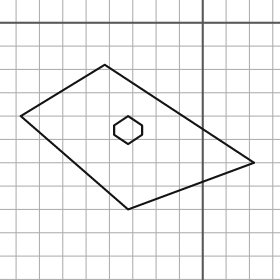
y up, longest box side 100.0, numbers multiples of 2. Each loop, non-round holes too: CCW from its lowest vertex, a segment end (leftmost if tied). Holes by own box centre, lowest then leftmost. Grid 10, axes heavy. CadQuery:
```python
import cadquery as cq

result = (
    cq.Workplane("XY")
    .moveTo(-32.0, -80.0)
    .lineTo(22.0, -60.0)
    .lineTo(-42.0, -18.0)
    .lineTo(-78.0, -40.0)
    .close()
    .moveTo(-32.0, -52.0)
    .lineTo(-26.0, -48.0)
    .lineTo(-26.0, -44.0)
    .lineTo(-32.0, -40.0)
    .lineTo(-38.0, -44.0)
    .lineTo(-38.0, -48.0)
    .close()
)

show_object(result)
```